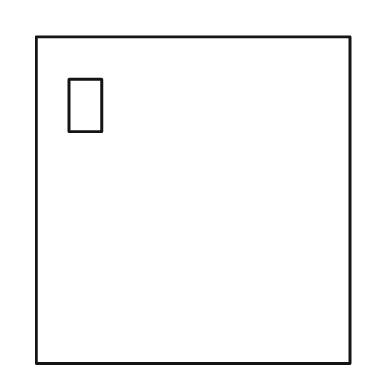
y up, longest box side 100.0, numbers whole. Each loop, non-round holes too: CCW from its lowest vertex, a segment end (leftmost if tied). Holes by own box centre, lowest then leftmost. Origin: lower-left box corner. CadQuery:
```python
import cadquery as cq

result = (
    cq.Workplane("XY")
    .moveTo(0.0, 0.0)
    .lineTo(96.0, 0.0)
    .lineTo(96.0, 100.0)
    .lineTo(0.0, 100.0)
    .close()
    .moveTo(10.0, 71.0)
    .lineTo(20.0, 71.0)
    .lineTo(20.0, 87.0)
    .lineTo(10.0, 87.0)
    .close()
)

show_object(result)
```